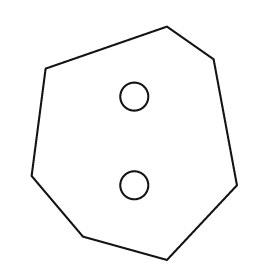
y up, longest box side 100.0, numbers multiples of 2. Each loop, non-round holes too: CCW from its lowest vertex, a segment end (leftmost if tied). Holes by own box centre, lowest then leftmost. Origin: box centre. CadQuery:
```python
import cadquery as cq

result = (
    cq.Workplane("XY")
    .moveTo(14.0, -50.0)
    .lineTo(44.0, -18.0)
    .lineTo(34.0, 36.0)
    .lineTo(14.0, 50.0)
    .lineTo(-38.0, 32.0)
    .lineTo(-44.0, -14.0)
    .lineTo(-22.0, -40.0)
    .close()
    .moveTo(0.0, -18.0)
    .circle(6.0)
    .moveTo(0.0, 20.0)
    .circle(6.0)
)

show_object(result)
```